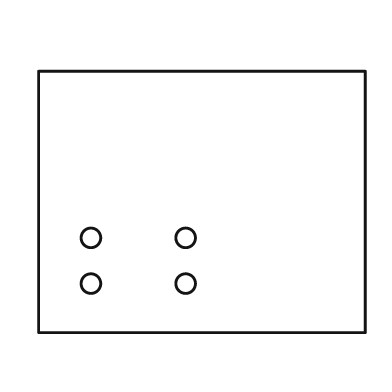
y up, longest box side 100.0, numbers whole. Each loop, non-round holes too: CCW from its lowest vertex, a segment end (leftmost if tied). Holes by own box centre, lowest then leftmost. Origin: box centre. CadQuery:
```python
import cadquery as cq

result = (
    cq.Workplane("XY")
    .moveTo(-50.0, -40.0)
    .lineTo(50.0, -40.0)
    .lineTo(50.0, 40.0)
    .lineTo(-50.0, 40.0)
    .close()
    .moveTo(-34.0, -25.0)
    .circle(3.0)
    .moveTo(-5.0, -25.0)
    .circle(3.0)
    .moveTo(-34.0, -11.0)
    .circle(3.0)
    .moveTo(-5.0, -11.0)
    .circle(3.0)
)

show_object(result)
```